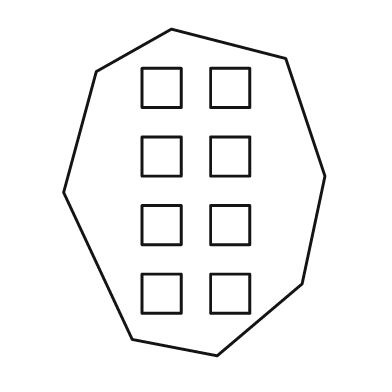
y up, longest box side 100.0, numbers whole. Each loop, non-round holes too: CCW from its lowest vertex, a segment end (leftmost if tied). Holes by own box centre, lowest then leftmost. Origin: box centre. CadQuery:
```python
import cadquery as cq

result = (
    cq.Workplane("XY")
    .moveTo(7.0, -50.0)
    .lineTo(33.0, -28.0)
    .lineTo(40.0, 5.0)
    .lineTo(28.0, 41.0)
    .lineTo(-7.0, 50.0)
    .lineTo(-30.0, 37.0)
    .lineTo(-40.0, 0.0)
    .lineTo(-19.0, -45.0)
    .close()
    .moveTo(-16.0, -37.0)
    .lineTo(-4.0, -37.0)
    .lineTo(-4.0, -25.0)
    .lineTo(-16.0, -25.0)
    .close()
    .moveTo(5.0, -37.0)
    .lineTo(17.0, -37.0)
    .lineTo(17.0, -25.0)
    .lineTo(5.0, -25.0)
    .close()
    .moveTo(-16.0, -16.0)
    .lineTo(-4.0, -16.0)
    .lineTo(-4.0, -4.0)
    .lineTo(-16.0, -4.0)
    .close()
    .moveTo(5.0, -16.0)
    .lineTo(17.0, -16.0)
    .lineTo(17.0, -4.0)
    .lineTo(5.0, -4.0)
    .close()
    .moveTo(-16.0, 5.0)
    .lineTo(-4.0, 5.0)
    .lineTo(-4.0, 17.0)
    .lineTo(-16.0, 17.0)
    .close()
    .moveTo(5.0, 5.0)
    .lineTo(17.0, 5.0)
    .lineTo(17.0, 17.0)
    .lineTo(5.0, 17.0)
    .close()
    .moveTo(-16.0, 26.0)
    .lineTo(-4.0, 26.0)
    .lineTo(-4.0, 38.0)
    .lineTo(-16.0, 38.0)
    .close()
    .moveTo(5.0, 26.0)
    .lineTo(17.0, 26.0)
    .lineTo(17.0, 38.0)
    .lineTo(5.0, 38.0)
    .close()
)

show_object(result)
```